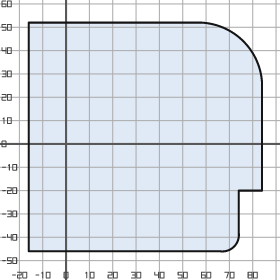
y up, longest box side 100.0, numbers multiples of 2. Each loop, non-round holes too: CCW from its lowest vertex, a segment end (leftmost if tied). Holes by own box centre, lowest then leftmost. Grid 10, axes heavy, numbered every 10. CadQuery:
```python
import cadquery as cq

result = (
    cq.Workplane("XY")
    .moveTo(-16.0, -46.0)
    .lineTo(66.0, -46.0)
    .threePointArc((72.0, -44.0), (74.0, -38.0))
    .lineTo(74.0, -20.0)
    .lineTo(84.0, -20.0)
    .lineTo(84.0, 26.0)
    .threePointArc((76.0, 44.0), (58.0, 52.0))
    .lineTo(-16.0, 52.0)
    .close()
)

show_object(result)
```